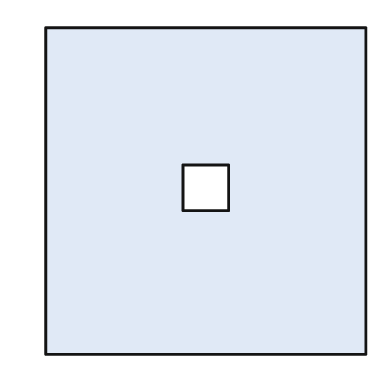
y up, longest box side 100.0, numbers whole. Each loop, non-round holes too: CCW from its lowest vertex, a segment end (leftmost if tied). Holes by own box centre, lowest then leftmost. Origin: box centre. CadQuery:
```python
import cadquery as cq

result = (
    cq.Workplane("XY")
    .moveTo(-49.0, -50.0)
    .lineTo(49.0, -50.0)
    .lineTo(49.0, 50.0)
    .lineTo(-49.0, 50.0)
    .close()
    .moveTo(-7.0, -6.0)
    .lineTo(7.0, -6.0)
    .lineTo(7.0, 8.0)
    .lineTo(-7.0, 8.0)
    .close()
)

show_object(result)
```